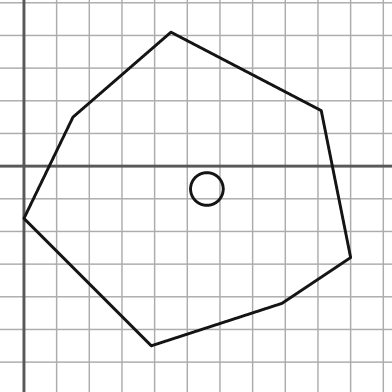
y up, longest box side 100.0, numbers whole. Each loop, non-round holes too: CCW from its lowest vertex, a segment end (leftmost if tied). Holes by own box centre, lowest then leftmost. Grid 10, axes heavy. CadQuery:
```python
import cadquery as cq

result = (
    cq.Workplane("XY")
    .moveTo(39.0, -55.0)
    .lineTo(79.0, -42.0)
    .lineTo(100.0, -28.0)
    .lineTo(91.0, 17.0)
    .lineTo(45.0, 41.0)
    .lineTo(15.0, 15.0)
    .lineTo(0.0, -16.0)
    .close()
    .moveTo(56.0, -7.0)
    .circle(5.0)
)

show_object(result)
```